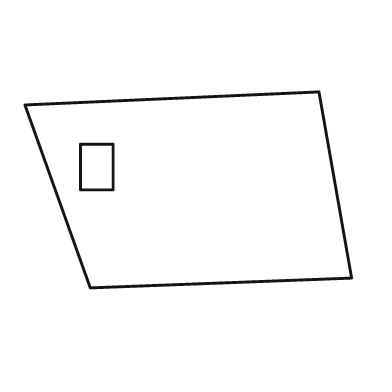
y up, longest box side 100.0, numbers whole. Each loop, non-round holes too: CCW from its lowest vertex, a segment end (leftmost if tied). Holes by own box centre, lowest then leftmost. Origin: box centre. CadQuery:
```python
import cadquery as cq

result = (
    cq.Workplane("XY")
    .moveTo(-30.0, -30.0)
    .lineTo(50.0, -27.0)
    .lineTo(40.0, 30.0)
    .lineTo(-50.0, 26.0)
    .close()
    .moveTo(-33.0, 0.0)
    .lineTo(-23.0, 0.0)
    .lineTo(-23.0, 14.0)
    .lineTo(-33.0, 14.0)
    .close()
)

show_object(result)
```